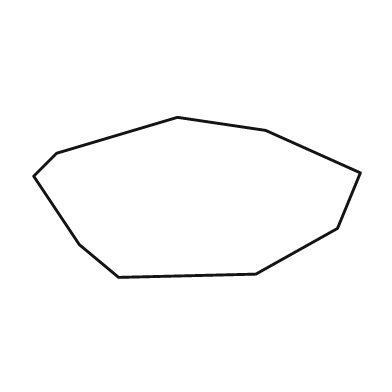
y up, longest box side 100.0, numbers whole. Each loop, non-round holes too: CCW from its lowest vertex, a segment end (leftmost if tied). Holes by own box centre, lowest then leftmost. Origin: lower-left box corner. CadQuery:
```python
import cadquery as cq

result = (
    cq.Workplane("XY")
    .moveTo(26.0, 0.0)
    .lineTo(68.0, 1.0)
    .lineTo(93.0, 15.0)
    .lineTo(100.0, 32.0)
    .lineTo(71.0, 45.0)
    .lineTo(44.0, 49.0)
    .lineTo(7.0, 38.0)
    .lineTo(0.0, 31.0)
    .lineTo(14.0, 10.0)
    .close()
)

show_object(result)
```